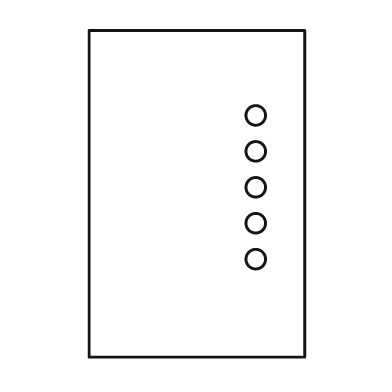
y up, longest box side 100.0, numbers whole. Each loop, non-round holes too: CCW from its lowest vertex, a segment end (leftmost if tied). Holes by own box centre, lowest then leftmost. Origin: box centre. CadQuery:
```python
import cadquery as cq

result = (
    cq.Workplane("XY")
    .moveTo(-33.0, -50.0)
    .lineTo(33.0, -50.0)
    .lineTo(33.0, 50.0)
    .lineTo(-33.0, 50.0)
    .close()
    .moveTo(18.0, -20.0)
    .circle(3.0)
    .moveTo(18.0, -9.0)
    .circle(3.0)
    .moveTo(18.0, 2.0)
    .circle(3.0)
    .moveTo(18.0, 13.0)
    .circle(3.0)
    .moveTo(18.0, 24.0)
    .circle(3.0)
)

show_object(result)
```